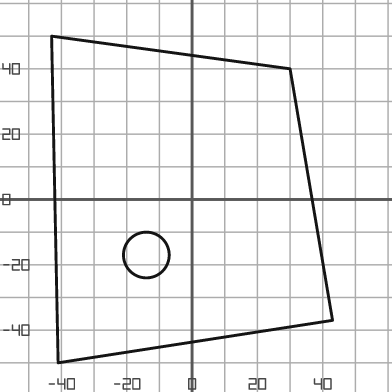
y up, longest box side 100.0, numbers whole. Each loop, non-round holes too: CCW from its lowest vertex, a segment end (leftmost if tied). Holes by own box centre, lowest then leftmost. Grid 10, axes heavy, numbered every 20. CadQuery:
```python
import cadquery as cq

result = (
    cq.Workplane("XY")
    .moveTo(-41.0, -50.0)
    .lineTo(43.0, -37.0)
    .lineTo(30.0, 40.0)
    .lineTo(-43.0, 50.0)
    .close()
    .moveTo(-14.0, -17.0)
    .circle(7.0)
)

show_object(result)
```